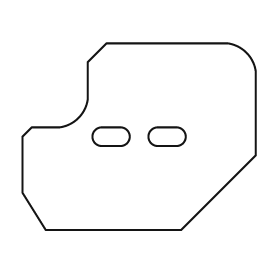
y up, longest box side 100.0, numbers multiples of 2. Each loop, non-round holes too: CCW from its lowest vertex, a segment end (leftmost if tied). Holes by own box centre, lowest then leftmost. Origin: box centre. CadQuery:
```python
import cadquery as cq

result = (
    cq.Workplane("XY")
    .moveTo(-40.0, -40.0)
    .lineTo(18.0, -40.0)
    .lineTo(50.0, -8.0)
    .lineTo(50.0, 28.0)
    .threePointArc((46.0, 36.0), (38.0, 40.0))
    .lineTo(-14.0, 40.0)
    .lineTo(-22.0, 32.0)
    .lineTo(-22.0, 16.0)
    .threePointArc((-26.0, 8.0), (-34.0, 4.0))
    .lineTo(-46.0, 4.0)
    .lineTo(-50.0, 0.0)
    .lineTo(-50.0, -24.0)
    .close()
    .moveTo(-16.0, -4.0)
    .lineTo(-8.0, -4.0)
    .threePointArc((-4.0, 0.0), (-8.0, 4.0))
    .lineTo(-16.0, 4.0)
    .threePointArc((-20.0, 0.0), (-16.0, -4.0))
    .close()
    .moveTo(8.0, -4.0)
    .lineTo(16.0, -4.0)
    .threePointArc((20.0, 0.0), (16.0, 4.0))
    .lineTo(8.0, 4.0)
    .threePointArc((4.0, 0.0), (8.0, -4.0))
    .close()
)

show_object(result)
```